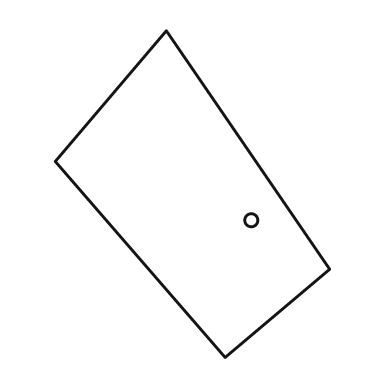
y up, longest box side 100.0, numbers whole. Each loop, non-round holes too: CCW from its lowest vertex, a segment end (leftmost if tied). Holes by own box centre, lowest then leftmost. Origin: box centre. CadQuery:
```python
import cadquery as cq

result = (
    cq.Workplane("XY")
    .moveTo(10.0, -50.0)
    .lineTo(42.0, -23.0)
    .lineTo(-8.0, 50.0)
    .lineTo(-42.0, 10.0)
    .close()
    .moveTo(18.0, -8.0)
    .circle(2.0)
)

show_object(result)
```